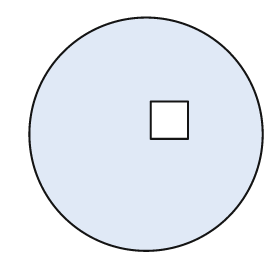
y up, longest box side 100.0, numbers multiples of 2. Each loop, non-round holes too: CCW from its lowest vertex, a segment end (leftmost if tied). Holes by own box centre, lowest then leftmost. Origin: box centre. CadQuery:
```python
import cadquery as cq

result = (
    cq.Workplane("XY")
    .moveTo(0.0, 0.0)
    .circle(50.0)
    .moveTo(2.0, -2.0)
    .lineTo(18.0, -2.0)
    .lineTo(18.0, 14.0)
    .lineTo(2.0, 14.0)
    .close()
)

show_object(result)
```